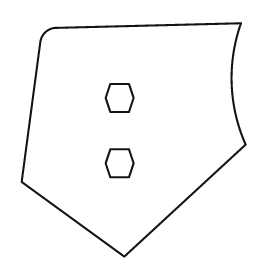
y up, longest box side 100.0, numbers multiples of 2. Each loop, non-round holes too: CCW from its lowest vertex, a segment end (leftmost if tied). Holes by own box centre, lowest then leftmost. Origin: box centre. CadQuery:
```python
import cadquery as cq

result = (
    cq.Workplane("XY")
    .moveTo(-4.0, -50.0)
    .lineTo(48.0, -2.0)
    .threePointArc((42.0, 24.0), (46.0, 50.0))
    .lineTo(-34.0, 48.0)
    .threePointArc((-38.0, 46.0), (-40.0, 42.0))
    .lineTo(-48.0, -18.0)
    .close()
    .moveTo(-10.0, -16.0)
    .lineTo(-2.0, -16.0)
    .lineTo(0.0, -10.0)
    .lineTo(-2.0, -4.0)
    .lineTo(-10.0, -4.0)
    .lineTo(-12.0, -10.0)
    .close()
    .moveTo(-10.0, 12.0)
    .lineTo(-2.0, 12.0)
    .lineTo(0.0, 18.0)
    .lineTo(-2.0, 24.0)
    .lineTo(-10.0, 24.0)
    .lineTo(-12.0, 18.0)
    .close()
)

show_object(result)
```